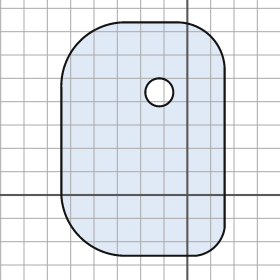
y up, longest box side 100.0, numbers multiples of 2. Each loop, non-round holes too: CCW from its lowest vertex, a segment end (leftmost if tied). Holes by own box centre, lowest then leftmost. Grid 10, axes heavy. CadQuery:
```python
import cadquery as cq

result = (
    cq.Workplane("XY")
    .moveTo(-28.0, -26.0)
    .lineTo(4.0, -26.0)
    .threePointArc((12.0, -22.0), (16.0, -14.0))
    .lineTo(16.0, 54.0)
    .threePointArc((10.0, 68.0), (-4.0, 74.0))
    .lineTo(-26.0, 74.0)
    .threePointArc((-46.0, 66.0), (-54.0, 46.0))
    .lineTo(-54.0, 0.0)
    .threePointArc((-46.0, -18.0), (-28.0, -26.0))
    .close()
    .moveTo(-12.0, 44.0)
    .circle(6.0)
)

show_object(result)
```